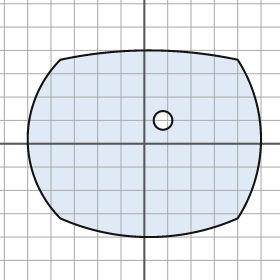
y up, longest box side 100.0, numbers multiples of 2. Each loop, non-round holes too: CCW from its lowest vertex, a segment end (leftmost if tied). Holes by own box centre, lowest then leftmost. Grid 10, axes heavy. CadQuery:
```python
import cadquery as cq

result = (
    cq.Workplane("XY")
    .moveTo(-36.0, -32.0)
    .threePointArc((2.0, -40.0), (40.0, -32.0))
    .threePointArc((50.0, 2.0), (40.0, 36.0))
    .threePointArc((2.0, 40.0), (-36.0, 36.0))
    .threePointArc((-50.0, 2.0), (-36.0, -32.0))
    .close()
    .moveTo(8.0, 10.0)
    .circle(4.0)
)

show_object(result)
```